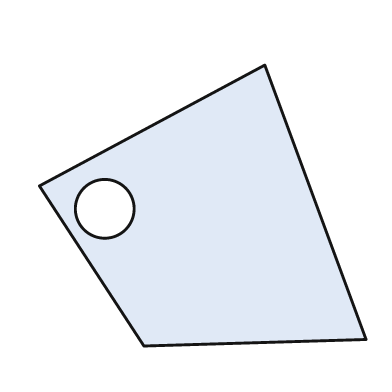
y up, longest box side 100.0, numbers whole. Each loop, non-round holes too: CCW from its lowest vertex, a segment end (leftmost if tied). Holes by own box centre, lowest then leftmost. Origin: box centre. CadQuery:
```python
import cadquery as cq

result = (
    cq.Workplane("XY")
    .moveTo(-18.0, -43.0)
    .lineTo(50.0, -41.0)
    .lineTo(19.0, 43.0)
    .lineTo(-50.0, 6.0)
    .close()
    .moveTo(-30.0, -1.0)
    .circle(9.0)
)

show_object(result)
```